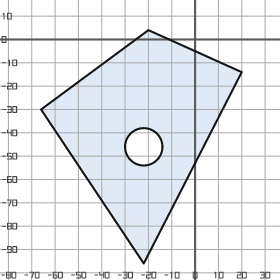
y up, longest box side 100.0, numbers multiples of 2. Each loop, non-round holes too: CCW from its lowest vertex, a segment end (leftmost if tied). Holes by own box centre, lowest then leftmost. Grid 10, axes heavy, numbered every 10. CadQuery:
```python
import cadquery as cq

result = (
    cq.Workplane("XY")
    .moveTo(-22.0, -96.0)
    .lineTo(20.0, -14.0)
    .lineTo(-20.0, 4.0)
    .lineTo(-66.0, -30.0)
    .close()
    .moveTo(-22.0, -46.0)
    .circle(8.0)
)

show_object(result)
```